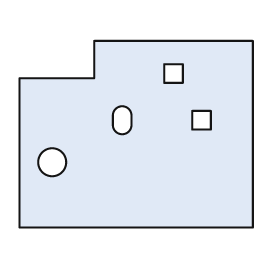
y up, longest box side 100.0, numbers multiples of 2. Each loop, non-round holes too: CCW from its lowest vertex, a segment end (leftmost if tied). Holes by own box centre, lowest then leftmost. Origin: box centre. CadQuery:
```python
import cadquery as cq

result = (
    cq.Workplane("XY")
    .moveTo(-50.0, -40.0)
    .lineTo(50.0, -40.0)
    .lineTo(50.0, 40.0)
    .lineTo(-18.0, 40.0)
    .lineTo(-18.0, 24.0)
    .lineTo(-50.0, 24.0)
    .close()
    .moveTo(-36.0, -12.0)
    .circle(6.0)
    .moveTo(-10.0, 4.0)
    .threePointArc((-6.0, 0.0), (-2.0, 4.0))
    .lineTo(-2.0, 8.0)
    .threePointArc((-6.0, 12.0), (-10.0, 8.0))
    .close()
    .moveTo(24.0, 2.0)
    .lineTo(32.0, 2.0)
    .lineTo(32.0, 10.0)
    .lineTo(24.0, 10.0)
    .close()
    .moveTo(12.0, 22.0)
    .lineTo(20.0, 22.0)
    .lineTo(20.0, 30.0)
    .lineTo(12.0, 30.0)
    .close()
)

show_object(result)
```